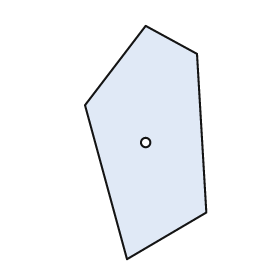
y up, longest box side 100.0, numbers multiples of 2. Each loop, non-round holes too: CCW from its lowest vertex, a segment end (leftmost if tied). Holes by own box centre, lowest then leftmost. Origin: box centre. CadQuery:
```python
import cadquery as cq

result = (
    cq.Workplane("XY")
    .moveTo(-8.0, -50.0)
    .lineTo(26.0, -30.0)
    .lineTo(22.0, 38.0)
    .lineTo(0.0, 50.0)
    .lineTo(-26.0, 16.0)
    .close()
    .moveTo(0.0, 0.0)
    .circle(2.0)
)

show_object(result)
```